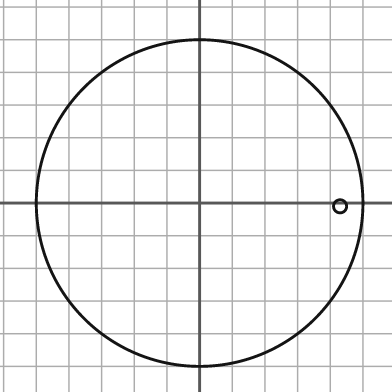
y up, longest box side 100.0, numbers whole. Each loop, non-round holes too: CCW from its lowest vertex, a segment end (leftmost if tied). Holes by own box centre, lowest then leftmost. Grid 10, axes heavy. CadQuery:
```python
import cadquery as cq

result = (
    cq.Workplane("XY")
    .moveTo(0.0, 0.0)
    .circle(50.0)
    .moveTo(43.0, -1.0)
    .circle(2.0)
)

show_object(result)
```